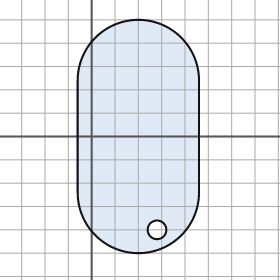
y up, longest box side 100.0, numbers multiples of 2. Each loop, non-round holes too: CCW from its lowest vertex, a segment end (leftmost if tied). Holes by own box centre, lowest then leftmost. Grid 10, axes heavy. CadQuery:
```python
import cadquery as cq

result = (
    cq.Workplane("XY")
    .moveTo(-6.0, -24.0)
    .threePointArc((20.0, -50.0), (46.0, -24.0))
    .lineTo(46.0, 24.0)
    .threePointArc((20.0, 50.0), (-6.0, 24.0))
    .close()
    .moveTo(28.0, -40.0)
    .circle(4.0)
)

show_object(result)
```